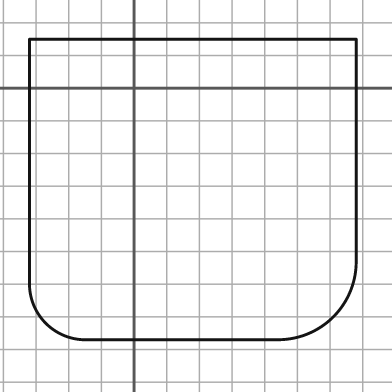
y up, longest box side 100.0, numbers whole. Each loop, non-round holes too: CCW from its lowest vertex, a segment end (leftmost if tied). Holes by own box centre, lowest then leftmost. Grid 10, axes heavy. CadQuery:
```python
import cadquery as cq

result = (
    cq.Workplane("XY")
    .moveTo(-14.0, -77.0)
    .lineTo(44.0, -77.0)
    .threePointArc((61.0, -70.0), (68.0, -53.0))
    .lineTo(68.0, 15.0)
    .lineTo(-32.0, 15.0)
    .lineTo(-32.0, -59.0)
    .threePointArc((-27.0, -72.0), (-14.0, -77.0))
    .close()
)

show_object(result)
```